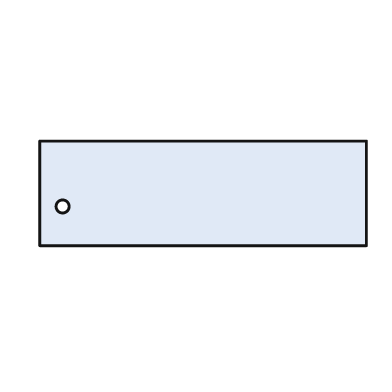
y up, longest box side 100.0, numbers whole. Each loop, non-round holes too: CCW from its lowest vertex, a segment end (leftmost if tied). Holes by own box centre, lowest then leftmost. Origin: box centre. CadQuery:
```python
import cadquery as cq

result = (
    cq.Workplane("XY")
    .moveTo(-50.0, -16.0)
    .lineTo(50.0, -16.0)
    .lineTo(50.0, 16.0)
    .lineTo(-50.0, 16.0)
    .close()
    .moveTo(-43.0, -4.0)
    .circle(2.0)
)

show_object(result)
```